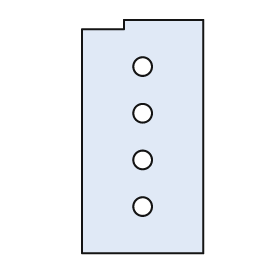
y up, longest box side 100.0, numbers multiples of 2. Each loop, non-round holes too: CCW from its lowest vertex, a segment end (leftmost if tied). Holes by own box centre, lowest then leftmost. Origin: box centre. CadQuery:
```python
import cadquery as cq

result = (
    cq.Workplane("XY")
    .moveTo(-26.0, -50.0)
    .lineTo(26.0, -50.0)
    .lineTo(26.0, 50.0)
    .lineTo(-8.0, 50.0)
    .lineTo(-8.0, 46.0)
    .lineTo(-26.0, 46.0)
    .close()
    .moveTo(0.0, -30.0)
    .circle(4.0)
    .moveTo(0.0, -10.0)
    .circle(4.0)
    .moveTo(0.0, 10.0)
    .circle(4.0)
    .moveTo(0.0, 30.0)
    .circle(4.0)
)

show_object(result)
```